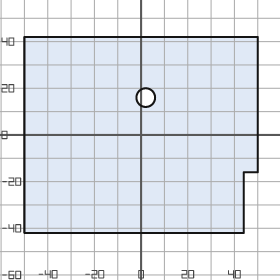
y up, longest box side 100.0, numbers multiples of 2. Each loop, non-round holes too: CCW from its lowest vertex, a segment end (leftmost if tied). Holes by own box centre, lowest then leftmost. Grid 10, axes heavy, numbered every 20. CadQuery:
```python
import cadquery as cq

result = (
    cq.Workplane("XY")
    .moveTo(-50.0, -42.0)
    .lineTo(44.0, -42.0)
    .lineTo(44.0, -16.0)
    .lineTo(50.0, -16.0)
    .lineTo(50.0, 42.0)
    .lineTo(-50.0, 42.0)
    .close()
    .moveTo(2.0, 16.0)
    .circle(4.0)
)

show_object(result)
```